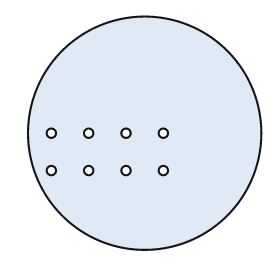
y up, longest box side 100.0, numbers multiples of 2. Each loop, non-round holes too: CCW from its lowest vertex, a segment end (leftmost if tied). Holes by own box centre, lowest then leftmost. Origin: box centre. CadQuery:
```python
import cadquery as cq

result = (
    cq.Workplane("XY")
    .moveTo(0.0, 0.0)
    .circle(50.0)
    .moveTo(-40.0, -16.0)
    .circle(2.0)
    .moveTo(-24.0, -16.0)
    .circle(2.0)
    .moveTo(-8.0, -16.0)
    .circle(2.0)
    .moveTo(8.0, -16.0)
    .circle(2.0)
    .moveTo(-40.0, 0.0)
    .circle(2.0)
    .moveTo(-24.0, 0.0)
    .circle(2.0)
    .moveTo(-8.0, 0.0)
    .circle(2.0)
    .moveTo(8.0, 0.0)
    .circle(2.0)
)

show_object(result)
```